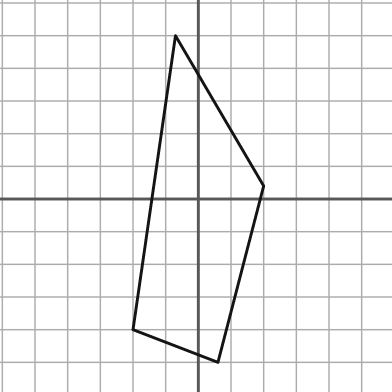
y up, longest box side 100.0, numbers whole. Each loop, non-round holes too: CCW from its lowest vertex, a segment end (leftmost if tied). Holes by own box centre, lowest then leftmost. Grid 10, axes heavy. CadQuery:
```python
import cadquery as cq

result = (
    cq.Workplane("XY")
    .moveTo(6.0, -50.0)
    .lineTo(20.0, 4.0)
    .lineTo(-7.0, 50.0)
    .lineTo(-20.0, -40.0)
    .close()
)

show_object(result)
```